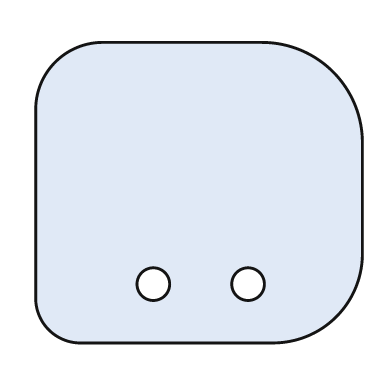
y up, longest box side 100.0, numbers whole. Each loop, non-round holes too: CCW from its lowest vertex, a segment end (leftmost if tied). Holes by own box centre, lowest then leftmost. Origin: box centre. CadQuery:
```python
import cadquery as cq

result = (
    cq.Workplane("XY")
    .moveTo(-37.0, -46.0)
    .lineTo(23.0, -46.0)
    .threePointArc((42.0, -38.0), (50.0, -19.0))
    .lineTo(50.0, 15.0)
    .threePointArc((41.0, 37.0), (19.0, 46.0))
    .lineTo(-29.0, 46.0)
    .threePointArc((-44.0, 40.0), (-50.0, 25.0))
    .lineTo(-50.0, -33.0)
    .threePointArc((-46.0, -42.0), (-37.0, -46.0))
    .close()
    .moveTo(-14.0, -28.0)
    .circle(5.0)
    .moveTo(15.0, -28.0)
    .circle(5.0)
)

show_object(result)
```